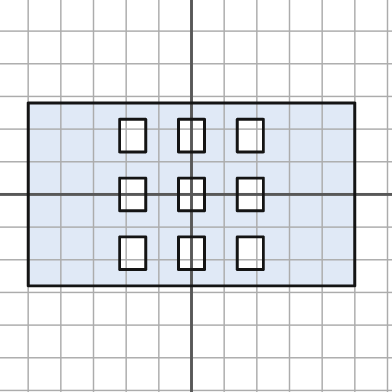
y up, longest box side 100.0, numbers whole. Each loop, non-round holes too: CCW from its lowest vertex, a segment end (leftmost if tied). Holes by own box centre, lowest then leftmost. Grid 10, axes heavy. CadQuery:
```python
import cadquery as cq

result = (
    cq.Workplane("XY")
    .moveTo(-50.0, -28.0)
    .lineTo(50.0, -28.0)
    .lineTo(50.0, 28.0)
    .lineTo(-50.0, 28.0)
    .close()
    .moveTo(-22.0, -23.0)
    .lineTo(-14.0, -23.0)
    .lineTo(-14.0, -13.0)
    .lineTo(-22.0, -13.0)
    .close()
    .moveTo(-4.0, -23.0)
    .lineTo(4.0, -23.0)
    .lineTo(4.0, -13.0)
    .lineTo(-4.0, -13.0)
    .close()
    .moveTo(14.0, -23.0)
    .lineTo(22.0, -23.0)
    .lineTo(22.0, -13.0)
    .lineTo(14.0, -13.0)
    .close()
    .moveTo(-22.0, -5.0)
    .lineTo(-14.0, -5.0)
    .lineTo(-14.0, 5.0)
    .lineTo(-22.0, 5.0)
    .close()
    .moveTo(-4.0, -5.0)
    .lineTo(4.0, -5.0)
    .lineTo(4.0, 5.0)
    .lineTo(-4.0, 5.0)
    .close()
    .moveTo(14.0, -5.0)
    .lineTo(22.0, -5.0)
    .lineTo(22.0, 5.0)
    .lineTo(14.0, 5.0)
    .close()
    .moveTo(-22.0, 13.0)
    .lineTo(-14.0, 13.0)
    .lineTo(-14.0, 23.0)
    .lineTo(-22.0, 23.0)
    .close()
    .moveTo(-4.0, 13.0)
    .lineTo(4.0, 13.0)
    .lineTo(4.0, 23.0)
    .lineTo(-4.0, 23.0)
    .close()
    .moveTo(14.0, 13.0)
    .lineTo(22.0, 13.0)
    .lineTo(22.0, 23.0)
    .lineTo(14.0, 23.0)
    .close()
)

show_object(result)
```